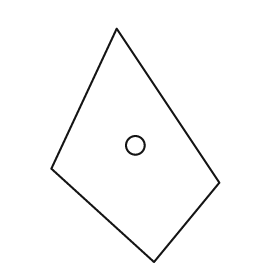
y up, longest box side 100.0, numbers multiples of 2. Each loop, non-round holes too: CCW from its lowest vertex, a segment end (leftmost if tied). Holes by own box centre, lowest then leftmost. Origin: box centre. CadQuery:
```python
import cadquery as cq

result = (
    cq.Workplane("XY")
    .moveTo(8.0, -50.0)
    .lineTo(36.0, -16.0)
    .lineTo(-8.0, 50.0)
    .lineTo(-36.0, -10.0)
    .close()
    .moveTo(0.0, 0.0)
    .circle(4.0)
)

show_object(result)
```